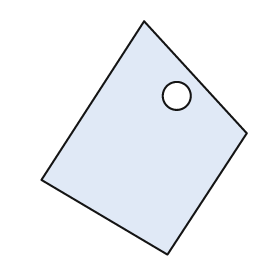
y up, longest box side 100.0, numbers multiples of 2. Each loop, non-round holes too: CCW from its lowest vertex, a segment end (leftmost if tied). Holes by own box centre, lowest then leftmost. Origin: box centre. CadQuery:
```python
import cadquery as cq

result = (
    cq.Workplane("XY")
    .moveTo(10.0, -50.0)
    .lineTo(44.0, 2.0)
    .lineTo(0.0, 50.0)
    .lineTo(-44.0, -18.0)
    .close()
    .moveTo(14.0, 18.0)
    .circle(6.0)
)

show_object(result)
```